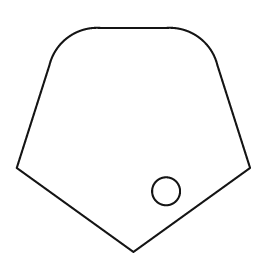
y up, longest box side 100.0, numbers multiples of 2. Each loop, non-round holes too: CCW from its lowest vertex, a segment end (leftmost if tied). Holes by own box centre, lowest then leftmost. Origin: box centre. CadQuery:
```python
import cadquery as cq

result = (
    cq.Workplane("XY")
    .moveTo(0.0, -48.0)
    .lineTo(50.0, -12.0)
    .lineTo(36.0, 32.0)
    .threePointArc((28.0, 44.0), (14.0, 48.0))
    .lineTo(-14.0, 48.0)
    .threePointArc((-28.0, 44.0), (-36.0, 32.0))
    .lineTo(-50.0, -12.0)
    .close()
    .moveTo(14.0, -22.0)
    .circle(6.0)
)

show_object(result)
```